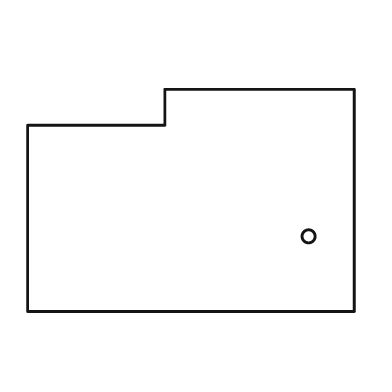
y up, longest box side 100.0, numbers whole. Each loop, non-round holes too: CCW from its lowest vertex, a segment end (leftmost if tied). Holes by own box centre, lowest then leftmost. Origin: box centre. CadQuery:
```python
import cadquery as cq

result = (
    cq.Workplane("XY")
    .moveTo(-50.0, -34.0)
    .lineTo(50.0, -34.0)
    .lineTo(50.0, 34.0)
    .lineTo(-8.0, 34.0)
    .lineTo(-8.0, 23.0)
    .lineTo(-50.0, 23.0)
    .close()
    .moveTo(36.0, -11.0)
    .circle(2.0)
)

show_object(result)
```